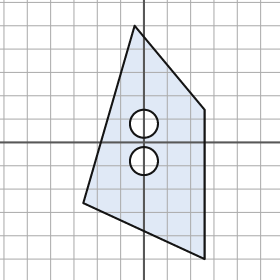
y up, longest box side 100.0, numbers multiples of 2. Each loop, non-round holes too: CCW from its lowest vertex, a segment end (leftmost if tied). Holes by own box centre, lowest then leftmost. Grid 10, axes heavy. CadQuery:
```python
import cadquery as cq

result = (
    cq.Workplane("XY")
    .moveTo(26.0, -50.0)
    .lineTo(26.0, 14.0)
    .lineTo(-4.0, 50.0)
    .lineTo(-26.0, -26.0)
    .close()
    .moveTo(0.0, -8.0)
    .circle(6.0)
    .moveTo(0.0, 8.0)
    .circle(6.0)
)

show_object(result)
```